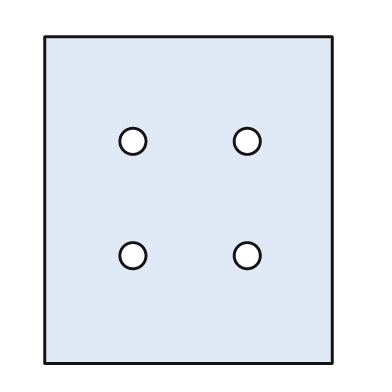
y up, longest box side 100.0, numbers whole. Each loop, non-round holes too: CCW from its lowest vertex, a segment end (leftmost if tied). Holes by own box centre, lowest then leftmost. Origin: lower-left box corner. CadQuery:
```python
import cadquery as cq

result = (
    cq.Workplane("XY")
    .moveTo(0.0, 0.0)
    .lineTo(88.0, 0.0)
    .lineTo(88.0, 100.0)
    .lineTo(0.0, 100.0)
    .close()
    .moveTo(27.0, 33.0)
    .circle(4.0)
    .moveTo(62.0, 33.0)
    .circle(4.0)
    .moveTo(27.0, 68.0)
    .circle(4.0)
    .moveTo(62.0, 68.0)
    .circle(4.0)
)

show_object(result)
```